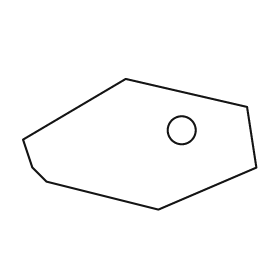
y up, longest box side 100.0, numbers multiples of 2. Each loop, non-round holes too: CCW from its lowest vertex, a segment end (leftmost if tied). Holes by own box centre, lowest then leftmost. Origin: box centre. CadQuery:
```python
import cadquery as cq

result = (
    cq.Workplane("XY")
    .moveTo(8.0, -28.0)
    .lineTo(50.0, -10.0)
    .lineTo(46.0, 16.0)
    .lineTo(-6.0, 28.0)
    .lineTo(-50.0, 2.0)
    .lineTo(-46.0, -10.0)
    .lineTo(-40.0, -16.0)
    .close()
    .moveTo(18.0, 6.0)
    .circle(6.0)
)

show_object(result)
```